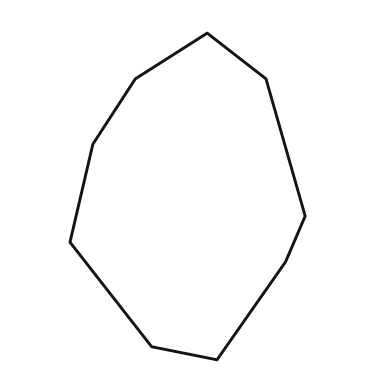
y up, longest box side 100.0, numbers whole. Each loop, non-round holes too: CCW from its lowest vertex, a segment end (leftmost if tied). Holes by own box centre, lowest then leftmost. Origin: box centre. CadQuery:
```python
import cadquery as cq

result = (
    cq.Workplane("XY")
    .moveTo(9.0, -50.0)
    .lineTo(30.0, -20.0)
    .lineTo(36.0, -6.0)
    .lineTo(24.0, 36.0)
    .lineTo(6.0, 50.0)
    .lineTo(-16.0, 36.0)
    .lineTo(-29.0, 16.0)
    .lineTo(-36.0, -14.0)
    .lineTo(-11.0, -46.0)
    .close()
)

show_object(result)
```